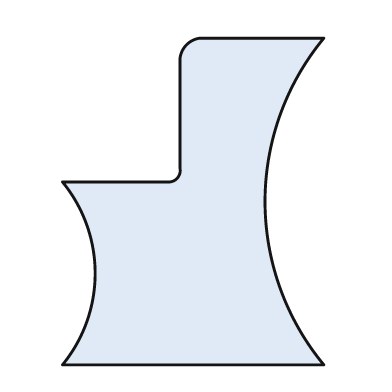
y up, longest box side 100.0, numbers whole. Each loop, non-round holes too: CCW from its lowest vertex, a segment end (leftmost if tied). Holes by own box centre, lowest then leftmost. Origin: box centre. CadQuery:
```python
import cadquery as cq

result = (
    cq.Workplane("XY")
    .moveTo(-40.0, -50.0)
    .lineTo(40.0, -50.0)
    .threePointArc((22.0, 0.0), (40.0, 50.0))
    .lineTo(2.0, 50.0)
    .threePointArc((-2.0, 48.0), (-4.0, 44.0))
    .lineTo(-4.0, 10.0)
    .threePointArc((-5.0, 7.0), (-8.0, 6.0))
    .lineTo(-40.0, 6.0)
    .threePointArc((-30.0, -22.0), (-40.0, -50.0))
    .close()
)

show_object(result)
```